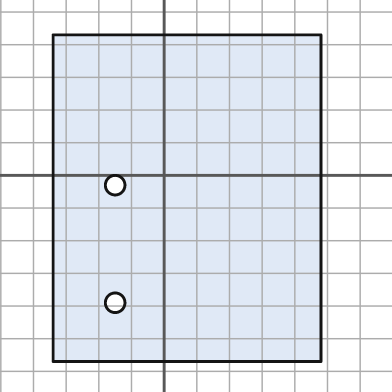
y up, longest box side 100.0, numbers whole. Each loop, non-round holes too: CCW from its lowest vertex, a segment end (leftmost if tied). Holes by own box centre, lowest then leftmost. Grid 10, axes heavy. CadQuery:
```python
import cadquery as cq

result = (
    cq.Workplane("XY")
    .moveTo(-34.0, -57.0)
    .lineTo(48.0, -57.0)
    .lineTo(48.0, 43.0)
    .lineTo(-34.0, 43.0)
    .close()
    .moveTo(-15.0, -39.0)
    .circle(3.0)
    .moveTo(-15.0, -3.0)
    .circle(3.0)
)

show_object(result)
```